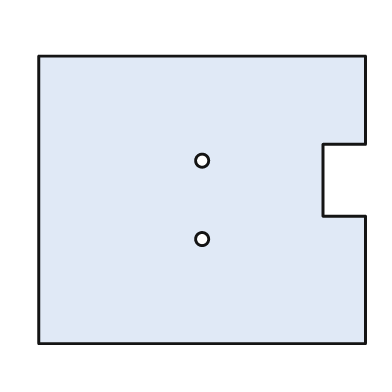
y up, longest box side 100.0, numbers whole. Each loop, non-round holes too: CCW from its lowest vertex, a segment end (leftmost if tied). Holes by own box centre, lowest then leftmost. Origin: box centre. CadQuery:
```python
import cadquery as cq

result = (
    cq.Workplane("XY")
    .moveTo(-50.0, -44.0)
    .lineTo(50.0, -44.0)
    .lineTo(50.0, -5.0)
    .lineTo(37.0, -5.0)
    .lineTo(37.0, 17.0)
    .lineTo(50.0, 17.0)
    .lineTo(50.0, 44.0)
    .lineTo(-50.0, 44.0)
    .close()
    .moveTo(0.0, -12.0)
    .circle(2.0)
    .moveTo(0.0, 12.0)
    .circle(2.0)
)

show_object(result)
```